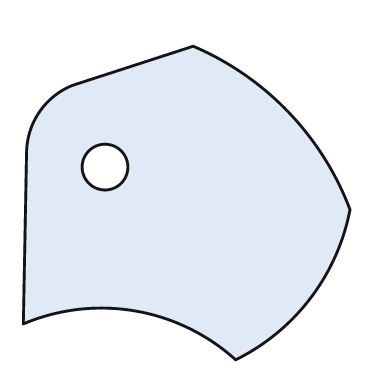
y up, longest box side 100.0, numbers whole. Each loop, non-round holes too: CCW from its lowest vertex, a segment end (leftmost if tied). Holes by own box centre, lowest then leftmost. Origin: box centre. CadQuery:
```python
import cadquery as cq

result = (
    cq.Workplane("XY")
    .moveTo(15.0, -48.0)
    .threePointArc((38.0, -29.0), (50.0, -2.0))
    .threePointArc((31.0, 28.0), (2.0, 48.0))
    .lineTo(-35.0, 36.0)
    .threePointArc((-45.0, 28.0), (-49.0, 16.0))
    .lineTo(-50.0, -37.0)
    .threePointArc((-16.0, -33.0), (15.0, -48.0))
    .close()
    .moveTo(-25.0, 11.0)
    .circle(7.0)
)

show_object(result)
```